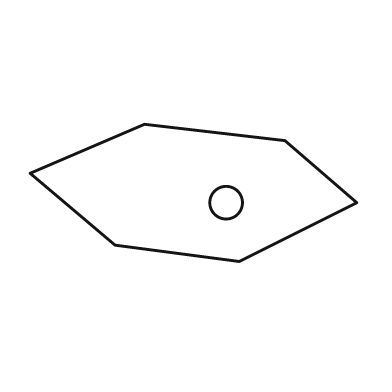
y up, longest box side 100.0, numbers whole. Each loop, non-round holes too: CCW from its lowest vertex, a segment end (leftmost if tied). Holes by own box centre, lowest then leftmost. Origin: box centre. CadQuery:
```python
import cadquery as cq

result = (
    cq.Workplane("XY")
    .moveTo(14.0, -21.0)
    .lineTo(50.0, -3.0)
    .lineTo(28.0, 16.0)
    .lineTo(-15.0, 21.0)
    .lineTo(-50.0, 6.0)
    .lineTo(-24.0, -16.0)
    .close()
    .moveTo(10.0, -3.0)
    .circle(5.0)
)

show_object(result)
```